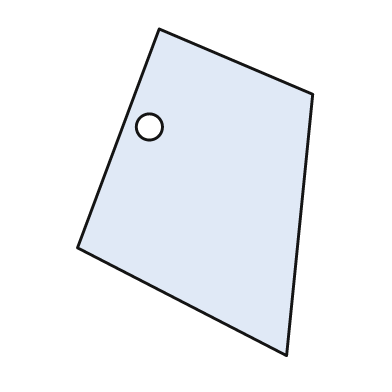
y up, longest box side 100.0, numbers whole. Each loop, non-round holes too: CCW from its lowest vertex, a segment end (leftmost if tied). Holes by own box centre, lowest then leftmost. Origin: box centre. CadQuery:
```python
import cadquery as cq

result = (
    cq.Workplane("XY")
    .moveTo(28.0, -50.0)
    .lineTo(36.0, 30.0)
    .lineTo(-11.0, 50.0)
    .lineTo(-36.0, -17.0)
    .close()
    .moveTo(-14.0, 20.0)
    .circle(4.0)
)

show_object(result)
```